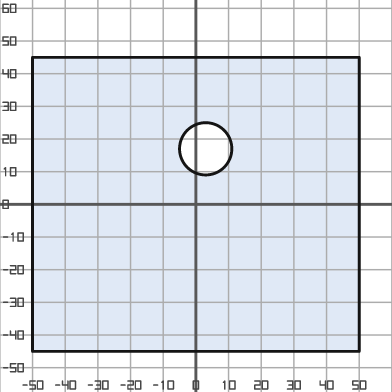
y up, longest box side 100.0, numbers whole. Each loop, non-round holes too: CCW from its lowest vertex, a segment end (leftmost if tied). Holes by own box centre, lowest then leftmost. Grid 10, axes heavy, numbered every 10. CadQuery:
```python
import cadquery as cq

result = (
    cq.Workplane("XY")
    .moveTo(-50.0, -45.0)
    .lineTo(50.0, -45.0)
    .lineTo(50.0, 45.0)
    .lineTo(-50.0, 45.0)
    .close()
    .moveTo(3.0, 17.0)
    .circle(8.0)
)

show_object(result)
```